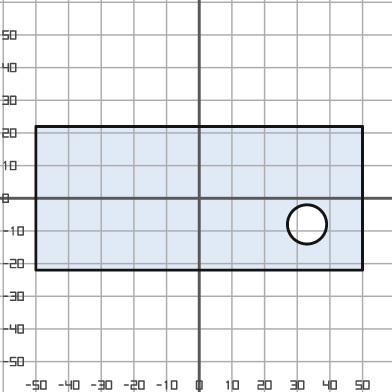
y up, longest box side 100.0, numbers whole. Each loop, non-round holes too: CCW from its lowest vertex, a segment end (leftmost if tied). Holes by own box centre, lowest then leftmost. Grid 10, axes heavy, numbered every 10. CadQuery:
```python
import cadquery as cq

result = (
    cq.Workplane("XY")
    .moveTo(-50.0, -22.0)
    .lineTo(50.0, -22.0)
    .lineTo(50.0, 22.0)
    .lineTo(-50.0, 22.0)
    .close()
    .moveTo(33.0, -8.0)
    .circle(6.0)
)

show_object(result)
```